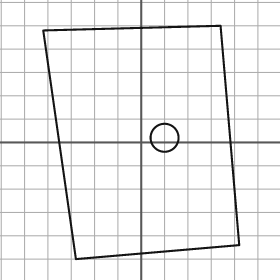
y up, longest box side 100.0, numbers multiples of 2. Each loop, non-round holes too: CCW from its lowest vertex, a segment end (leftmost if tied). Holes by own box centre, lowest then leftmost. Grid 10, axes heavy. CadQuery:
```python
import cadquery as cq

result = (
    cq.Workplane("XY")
    .moveTo(-28.0, -50.0)
    .lineTo(42.0, -44.0)
    .lineTo(34.0, 50.0)
    .lineTo(-42.0, 48.0)
    .close()
    .moveTo(10.0, 2.0)
    .circle(6.0)
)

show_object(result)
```